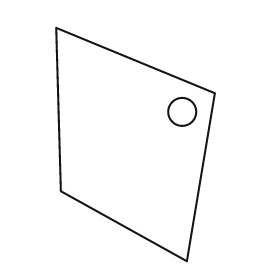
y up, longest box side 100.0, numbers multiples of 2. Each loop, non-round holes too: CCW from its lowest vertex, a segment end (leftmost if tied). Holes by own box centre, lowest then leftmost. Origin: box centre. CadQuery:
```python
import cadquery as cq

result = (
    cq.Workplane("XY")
    .moveTo(22.0, -50.0)
    .lineTo(34.0, 22.0)
    .lineTo(-34.0, 50.0)
    .lineTo(-32.0, -20.0)
    .close()
    .moveTo(20.0, 14.0)
    .circle(6.0)
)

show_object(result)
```